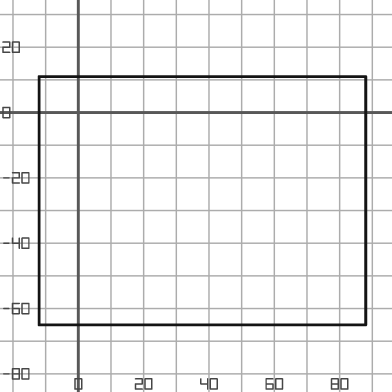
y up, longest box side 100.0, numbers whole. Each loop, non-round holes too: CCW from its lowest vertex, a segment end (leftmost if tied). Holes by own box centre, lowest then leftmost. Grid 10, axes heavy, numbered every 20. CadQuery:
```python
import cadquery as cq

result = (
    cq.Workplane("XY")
    .moveTo(-12.0, -65.0)
    .lineTo(88.0, -65.0)
    .lineTo(88.0, 11.0)
    .lineTo(-12.0, 11.0)
    .close()
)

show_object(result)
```